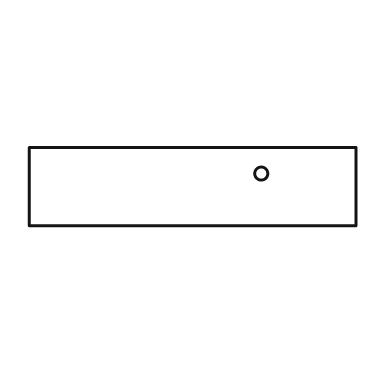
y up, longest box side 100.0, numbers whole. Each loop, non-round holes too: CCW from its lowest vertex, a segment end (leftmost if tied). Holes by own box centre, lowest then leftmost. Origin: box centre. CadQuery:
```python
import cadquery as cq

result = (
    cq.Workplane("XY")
    .moveTo(-50.0, -12.0)
    .lineTo(50.0, -12.0)
    .lineTo(50.0, 12.0)
    .lineTo(-50.0, 12.0)
    .close()
    .moveTo(21.0, 4.0)
    .circle(2.0)
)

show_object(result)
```